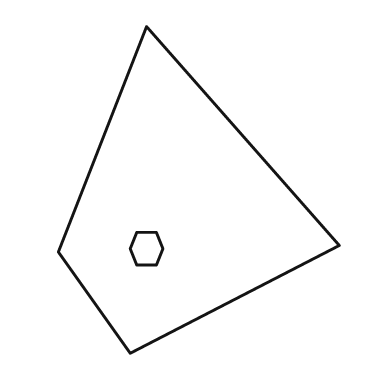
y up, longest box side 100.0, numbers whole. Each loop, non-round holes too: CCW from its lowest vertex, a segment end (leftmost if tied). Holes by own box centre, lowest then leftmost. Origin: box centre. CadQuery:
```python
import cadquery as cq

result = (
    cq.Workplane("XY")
    .moveTo(-21.0, -50.0)
    .lineTo(43.0, -17.0)
    .lineTo(-16.0, 50.0)
    .lineTo(-43.0, -19.0)
    .close()
    .moveTo(-19.0, -23.0)
    .lineTo(-13.0, -23.0)
    .lineTo(-11.0, -18.0)
    .lineTo(-13.0, -13.0)
    .lineTo(-19.0, -13.0)
    .lineTo(-21.0, -18.0)
    .close()
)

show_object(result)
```